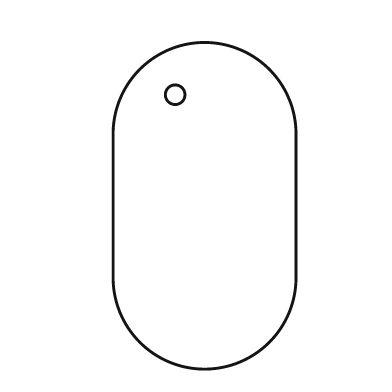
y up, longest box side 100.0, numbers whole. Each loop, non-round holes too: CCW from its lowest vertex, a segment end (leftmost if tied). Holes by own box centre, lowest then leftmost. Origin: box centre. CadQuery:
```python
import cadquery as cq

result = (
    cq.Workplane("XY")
    .moveTo(-28.0, -22.0)
    .threePointArc((0.0, -50.0), (28.0, -22.0))
    .lineTo(28.0, 22.0)
    .threePointArc((0.0, 50.0), (-28.0, 22.0))
    .close()
    .moveTo(-9.0, 34.0)
    .circle(3.0)
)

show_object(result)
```